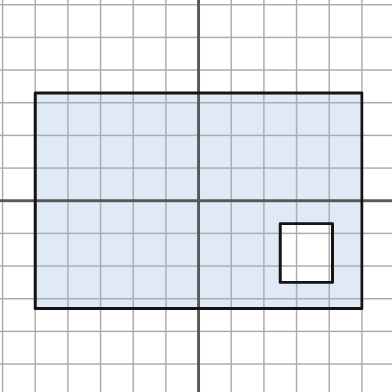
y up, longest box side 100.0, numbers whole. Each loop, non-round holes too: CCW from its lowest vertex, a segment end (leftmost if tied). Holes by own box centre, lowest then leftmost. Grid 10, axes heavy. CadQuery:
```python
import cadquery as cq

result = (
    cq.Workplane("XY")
    .moveTo(-50.0, -33.0)
    .lineTo(50.0, -33.0)
    .lineTo(50.0, 33.0)
    .lineTo(-50.0, 33.0)
    .close()
    .moveTo(25.0, -25.0)
    .lineTo(41.0, -25.0)
    .lineTo(41.0, -7.0)
    .lineTo(25.0, -7.0)
    .close()
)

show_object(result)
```